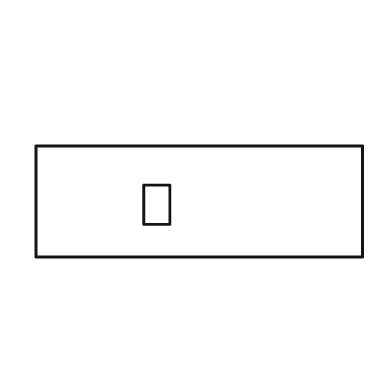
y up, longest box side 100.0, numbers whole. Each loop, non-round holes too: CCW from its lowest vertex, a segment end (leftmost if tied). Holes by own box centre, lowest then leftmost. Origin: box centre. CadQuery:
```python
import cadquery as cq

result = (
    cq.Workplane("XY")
    .moveTo(-50.0, -17.0)
    .lineTo(50.0, -17.0)
    .lineTo(50.0, 17.0)
    .lineTo(-50.0, 17.0)
    .close()
    .moveTo(-17.0, -7.0)
    .lineTo(-9.0, -7.0)
    .lineTo(-9.0, 5.0)
    .lineTo(-17.0, 5.0)
    .close()
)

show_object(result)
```